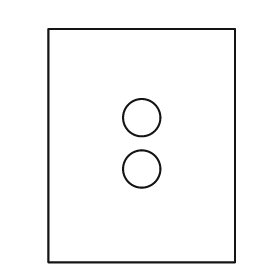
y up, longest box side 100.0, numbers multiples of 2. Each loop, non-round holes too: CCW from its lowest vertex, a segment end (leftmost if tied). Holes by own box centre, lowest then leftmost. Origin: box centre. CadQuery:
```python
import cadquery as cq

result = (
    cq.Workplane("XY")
    .moveTo(-40.0, -50.0)
    .lineTo(40.0, -50.0)
    .lineTo(40.0, 50.0)
    .lineTo(-40.0, 50.0)
    .close()
    .moveTo(0.0, -10.0)
    .circle(8.0)
    .moveTo(0.0, 12.0)
    .circle(8.0)
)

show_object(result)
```